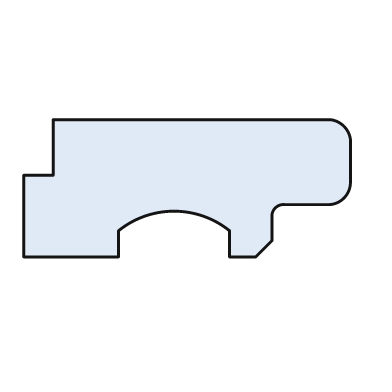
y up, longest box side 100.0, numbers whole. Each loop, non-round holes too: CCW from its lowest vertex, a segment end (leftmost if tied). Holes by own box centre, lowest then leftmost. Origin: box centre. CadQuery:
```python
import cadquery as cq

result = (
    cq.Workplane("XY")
    .moveTo(-50.0, -21.0)
    .lineTo(-21.0, -21.0)
    .lineTo(-21.0, -13.0)
    .threePointArc((-4.0, -7.0), (13.0, -13.0))
    .lineTo(13.0, -21.0)
    .lineTo(21.0, -21.0)
    .lineTo(26.0, -16.0)
    .lineTo(26.0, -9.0)
    .threePointArc((27.0, -6.0), (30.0, -5.0))
    .lineTo(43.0, -5.0)
    .threePointArc((48.0, -3.0), (50.0, 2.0))
    .lineTo(50.0, 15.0)
    .threePointArc((48.0, 19.0), (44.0, 21.0))
    .lineTo(-41.0, 21.0)
    .lineTo(-41.0, 4.0)
    .lineTo(-50.0, 4.0)
    .close()
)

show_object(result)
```